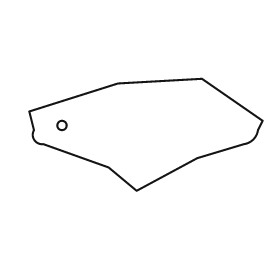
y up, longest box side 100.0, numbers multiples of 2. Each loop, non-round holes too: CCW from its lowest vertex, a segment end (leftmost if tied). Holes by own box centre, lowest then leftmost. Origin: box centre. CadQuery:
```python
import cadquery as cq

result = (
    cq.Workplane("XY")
    .moveTo(-4.0, -24.0)
    .lineTo(22.0, -10.0)
    .lineTo(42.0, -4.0)
    .threePointArc((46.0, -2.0), (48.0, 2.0))
    .lineTo(50.0, 6.0)
    .lineTo(24.0, 24.0)
    .lineTo(-12.0, 22.0)
    .lineTo(-50.0, 10.0)
    .lineTo(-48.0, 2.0)
    .threePointArc((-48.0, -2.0), (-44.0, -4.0))
    .lineTo(-16.0, -14.0)
    .close()
    .moveTo(-36.0, 4.0)
    .circle(2.0)
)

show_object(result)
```